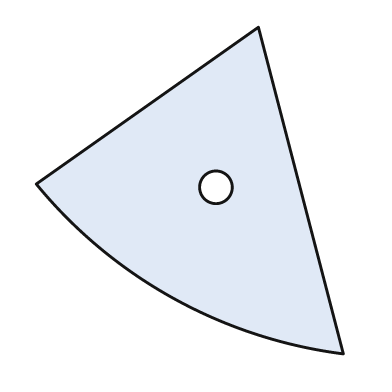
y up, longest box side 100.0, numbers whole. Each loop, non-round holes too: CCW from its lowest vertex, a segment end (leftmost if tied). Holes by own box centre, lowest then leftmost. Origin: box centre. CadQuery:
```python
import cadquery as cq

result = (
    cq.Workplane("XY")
    .moveTo(47.0, -50.0)
    .lineTo(21.0, 50.0)
    .lineTo(-47.0, 2.0)
    .threePointArc((-5.0, -33.0), (47.0, -50.0))
    .close()
    .moveTo(8.0, 1.0)
    .circle(5.0)
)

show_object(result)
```